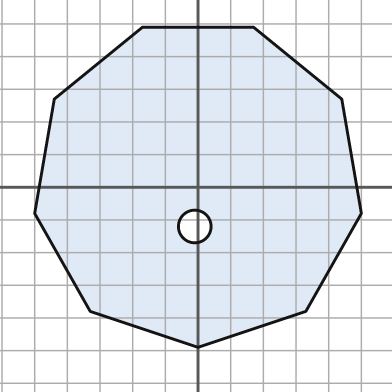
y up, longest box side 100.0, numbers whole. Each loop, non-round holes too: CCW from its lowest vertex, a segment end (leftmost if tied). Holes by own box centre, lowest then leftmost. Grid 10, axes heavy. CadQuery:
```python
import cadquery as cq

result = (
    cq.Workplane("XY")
    .moveTo(0.0, -49.0)
    .lineTo(33.0, -38.0)
    .lineTo(50.0, -8.0)
    .lineTo(44.0, 27.0)
    .lineTo(17.0, 49.0)
    .lineTo(-17.0, 49.0)
    .lineTo(-44.0, 27.0)
    .lineTo(-50.0, -8.0)
    .lineTo(-33.0, -38.0)
    .close()
    .moveTo(-1.0, -12.0)
    .circle(5.0)
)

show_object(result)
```